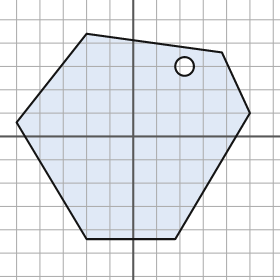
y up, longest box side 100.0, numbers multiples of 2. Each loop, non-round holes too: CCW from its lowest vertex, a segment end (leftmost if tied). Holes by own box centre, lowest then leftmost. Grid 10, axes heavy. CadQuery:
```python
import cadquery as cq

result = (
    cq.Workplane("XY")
    .moveTo(-20.0, -44.0)
    .lineTo(18.0, -44.0)
    .lineTo(50.0, 10.0)
    .lineTo(38.0, 36.0)
    .lineTo(-20.0, 44.0)
    .lineTo(-50.0, 6.0)
    .close()
    .moveTo(22.0, 30.0)
    .circle(4.0)
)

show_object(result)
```